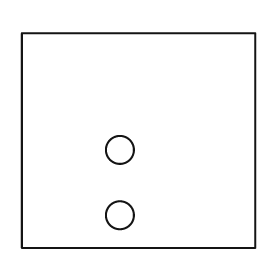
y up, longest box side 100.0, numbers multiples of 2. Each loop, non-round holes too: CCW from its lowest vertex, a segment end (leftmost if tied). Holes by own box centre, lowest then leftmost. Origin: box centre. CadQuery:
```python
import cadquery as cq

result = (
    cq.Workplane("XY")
    .moveTo(-50.0, -46.0)
    .lineTo(50.0, -46.0)
    .lineTo(50.0, 46.0)
    .lineTo(-50.0, 46.0)
    .close()
    .moveTo(-8.0, -32.0)
    .circle(6.0)
    .moveTo(-8.0, -4.0)
    .circle(6.0)
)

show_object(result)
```